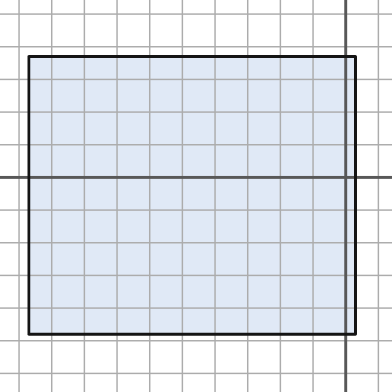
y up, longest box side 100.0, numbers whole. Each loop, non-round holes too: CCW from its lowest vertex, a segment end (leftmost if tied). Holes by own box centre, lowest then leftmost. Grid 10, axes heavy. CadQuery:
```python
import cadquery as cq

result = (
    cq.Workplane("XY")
    .moveTo(-97.0, -48.0)
    .lineTo(3.0, -48.0)
    .lineTo(3.0, 37.0)
    .lineTo(-97.0, 37.0)
    .close()
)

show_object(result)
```